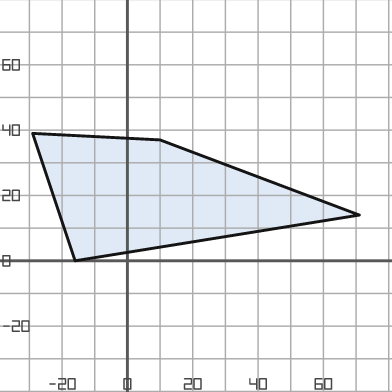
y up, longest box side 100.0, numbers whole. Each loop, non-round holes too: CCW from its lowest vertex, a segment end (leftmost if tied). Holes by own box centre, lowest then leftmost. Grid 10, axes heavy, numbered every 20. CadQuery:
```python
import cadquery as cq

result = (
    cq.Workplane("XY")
    .moveTo(-16.0, 0.0)
    .lineTo(71.0, 14.0)
    .lineTo(10.0, 37.0)
    .lineTo(-29.0, 39.0)
    .close()
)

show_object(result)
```